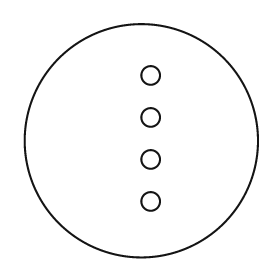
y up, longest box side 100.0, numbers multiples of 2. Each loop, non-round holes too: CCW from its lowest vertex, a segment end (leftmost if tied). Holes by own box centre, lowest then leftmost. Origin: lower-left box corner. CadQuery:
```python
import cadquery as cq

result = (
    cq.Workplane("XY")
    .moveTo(50.0, 50.0)
    .circle(50.0)
    .moveTo(54.0, 24.0)
    .circle(4.0)
    .moveTo(54.0, 42.0)
    .circle(4.0)
    .moveTo(54.0, 60.0)
    .circle(4.0)
    .moveTo(54.0, 78.0)
    .circle(4.0)
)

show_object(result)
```